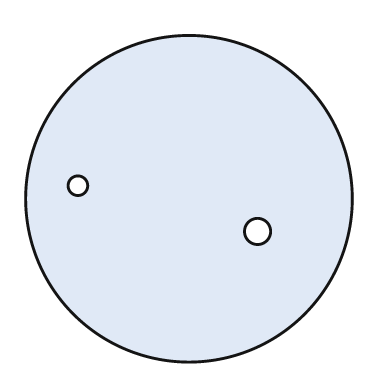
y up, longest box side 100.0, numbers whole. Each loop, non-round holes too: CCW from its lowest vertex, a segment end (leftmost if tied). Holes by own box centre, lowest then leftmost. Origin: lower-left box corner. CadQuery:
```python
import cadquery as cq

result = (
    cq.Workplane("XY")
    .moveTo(50.0, 50.0)
    .circle(50.0)
    .moveTo(71.0, 40.0)
    .circle(4.0)
    .moveTo(16.0, 54.0)
    .circle(3.0)
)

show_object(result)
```